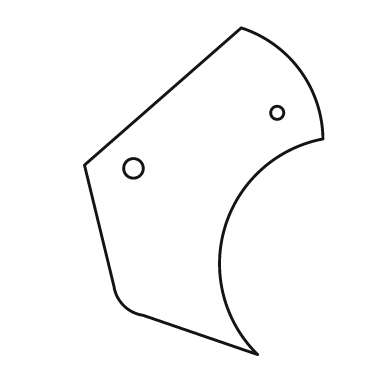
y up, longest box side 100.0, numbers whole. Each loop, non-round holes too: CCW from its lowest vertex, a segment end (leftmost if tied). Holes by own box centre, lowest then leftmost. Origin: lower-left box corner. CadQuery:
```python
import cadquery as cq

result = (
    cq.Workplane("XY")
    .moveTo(53.0, 0.0)
    .threePointArc((43.0, 39.0), (73.0, 66.0))
    .threePointArc((66.0, 87.0), (48.0, 100.0))
    .lineTo(0.0, 58.0)
    .lineTo(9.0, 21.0)
    .threePointArc((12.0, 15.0), (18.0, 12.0))
    .close()
    .moveTo(15.0, 57.0)
    .circle(3.0)
    .moveTo(59.0, 74.0)
    .circle(2.0)
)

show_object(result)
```